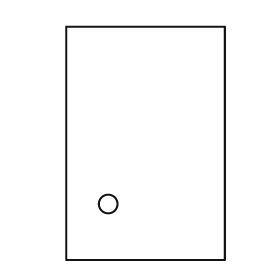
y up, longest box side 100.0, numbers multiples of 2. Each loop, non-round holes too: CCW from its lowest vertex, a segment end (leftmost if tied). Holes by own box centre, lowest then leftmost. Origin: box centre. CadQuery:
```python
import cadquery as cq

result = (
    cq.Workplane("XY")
    .moveTo(-34.0, -50.0)
    .lineTo(34.0, -50.0)
    .lineTo(34.0, 50.0)
    .lineTo(-34.0, 50.0)
    .close()
    .moveTo(-16.0, -26.0)
    .circle(4.0)
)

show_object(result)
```